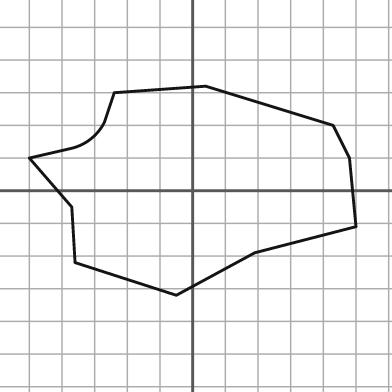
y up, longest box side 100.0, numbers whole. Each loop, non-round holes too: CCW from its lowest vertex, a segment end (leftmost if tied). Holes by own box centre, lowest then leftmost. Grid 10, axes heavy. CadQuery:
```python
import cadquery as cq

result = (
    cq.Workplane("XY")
    .moveTo(-5.0, -32.0)
    .lineTo(19.0, -19.0)
    .lineTo(50.0, -11.0)
    .lineTo(48.0, 10.0)
    .lineTo(43.0, 20.0)
    .lineTo(4.0, 32.0)
    .lineTo(-24.0, 30.0)
    .lineTo(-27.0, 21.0)
    .threePointArc((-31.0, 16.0), (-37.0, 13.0))
    .lineTo(-50.0, 10.0)
    .lineTo(-37.0, -5.0)
    .lineTo(-36.0, -22.0)
    .close()
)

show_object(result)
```